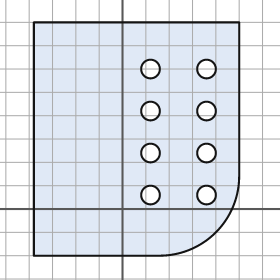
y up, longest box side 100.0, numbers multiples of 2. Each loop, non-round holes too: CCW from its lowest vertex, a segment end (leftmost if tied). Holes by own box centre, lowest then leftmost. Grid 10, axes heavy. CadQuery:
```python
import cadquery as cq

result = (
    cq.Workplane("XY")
    .moveTo(-38.0, -20.0)
    .lineTo(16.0, -20.0)
    .threePointArc((40.0, -10.0), (50.0, 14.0))
    .lineTo(50.0, 80.0)
    .lineTo(-38.0, 80.0)
    .close()
    .moveTo(12.0, 6.0)
    .circle(4.0)
    .moveTo(36.0, 6.0)
    .circle(4.0)
    .moveTo(12.0, 24.0)
    .circle(4.0)
    .moveTo(36.0, 24.0)
    .circle(4.0)
    .moveTo(12.0, 42.0)
    .circle(4.0)
    .moveTo(36.0, 42.0)
    .circle(4.0)
    .moveTo(12.0, 60.0)
    .circle(4.0)
    .moveTo(36.0, 60.0)
    .circle(4.0)
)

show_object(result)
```